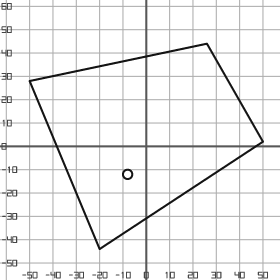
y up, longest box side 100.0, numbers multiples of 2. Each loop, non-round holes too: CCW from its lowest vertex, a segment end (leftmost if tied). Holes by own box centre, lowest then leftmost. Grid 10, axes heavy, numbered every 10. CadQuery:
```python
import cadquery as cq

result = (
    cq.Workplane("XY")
    .moveTo(-20.0, -44.0)
    .lineTo(50.0, 2.0)
    .lineTo(26.0, 44.0)
    .lineTo(-50.0, 28.0)
    .close()
    .moveTo(-8.0, -12.0)
    .circle(2.0)
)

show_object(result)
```